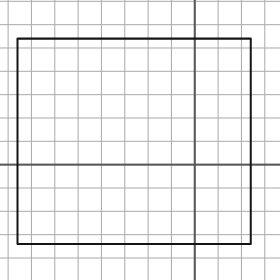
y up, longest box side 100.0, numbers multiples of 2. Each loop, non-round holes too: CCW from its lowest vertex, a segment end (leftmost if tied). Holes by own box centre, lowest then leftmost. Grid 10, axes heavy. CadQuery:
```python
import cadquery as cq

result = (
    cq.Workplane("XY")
    .moveTo(-76.0, -34.0)
    .lineTo(24.0, -34.0)
    .lineTo(24.0, 54.0)
    .lineTo(-76.0, 54.0)
    .close()
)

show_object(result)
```